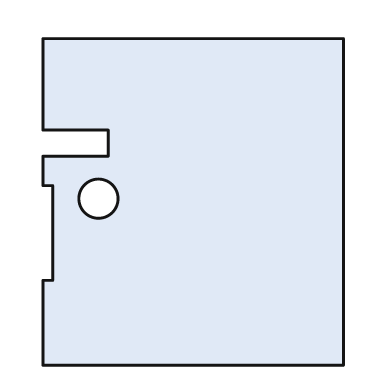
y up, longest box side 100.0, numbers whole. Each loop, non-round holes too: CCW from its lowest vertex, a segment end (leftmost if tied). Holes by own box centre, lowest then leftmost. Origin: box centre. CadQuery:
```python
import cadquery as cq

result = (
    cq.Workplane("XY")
    .moveTo(-46.0, -50.0)
    .lineTo(46.0, -50.0)
    .lineTo(46.0, 50.0)
    .lineTo(-46.0, 50.0)
    .lineTo(-46.0, 22.0)
    .lineTo(-26.0, 22.0)
    .lineTo(-26.0, 14.0)
    .lineTo(-46.0, 14.0)
    .lineTo(-46.0, 5.0)
    .lineTo(-43.0, 5.0)
    .lineTo(-43.0, -24.0)
    .lineTo(-46.0, -24.0)
    .close()
    .moveTo(-29.0, 1.0)
    .circle(6.0)
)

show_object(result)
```